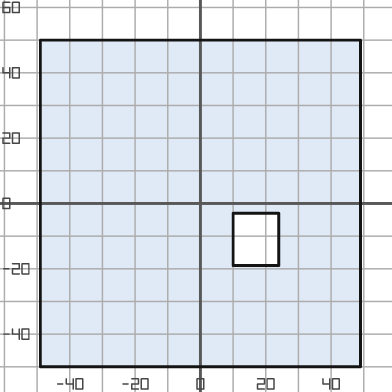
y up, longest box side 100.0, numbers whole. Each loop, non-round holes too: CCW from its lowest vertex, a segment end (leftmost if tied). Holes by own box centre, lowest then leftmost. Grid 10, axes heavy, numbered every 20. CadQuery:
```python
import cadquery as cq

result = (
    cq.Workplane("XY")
    .moveTo(-49.0, -50.0)
    .lineTo(49.0, -50.0)
    .lineTo(49.0, 50.0)
    .lineTo(-49.0, 50.0)
    .close()
    .moveTo(10.0, -19.0)
    .lineTo(24.0, -19.0)
    .lineTo(24.0, -3.0)
    .lineTo(10.0, -3.0)
    .close()
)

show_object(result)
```